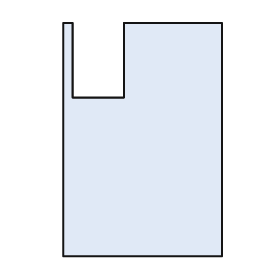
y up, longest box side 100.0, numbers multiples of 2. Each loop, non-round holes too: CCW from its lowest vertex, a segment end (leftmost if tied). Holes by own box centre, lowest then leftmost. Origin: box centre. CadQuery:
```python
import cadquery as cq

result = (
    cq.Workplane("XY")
    .moveTo(-34.0, -50.0)
    .lineTo(34.0, -50.0)
    .lineTo(34.0, 50.0)
    .lineTo(-8.0, 50.0)
    .lineTo(-8.0, 18.0)
    .lineTo(-30.0, 18.0)
    .lineTo(-30.0, 50.0)
    .lineTo(-34.0, 50.0)
    .close()
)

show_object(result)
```